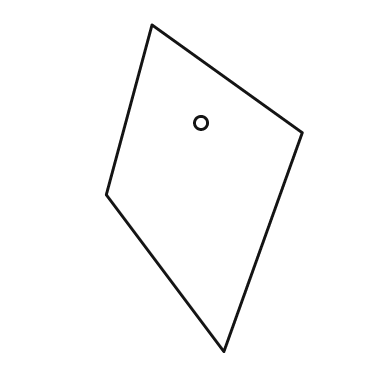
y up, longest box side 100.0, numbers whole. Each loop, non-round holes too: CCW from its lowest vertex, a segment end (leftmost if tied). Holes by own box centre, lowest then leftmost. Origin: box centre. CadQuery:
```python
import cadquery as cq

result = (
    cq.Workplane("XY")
    .moveTo(6.0, -50.0)
    .lineTo(30.0, 17.0)
    .lineTo(-16.0, 50.0)
    .lineTo(-30.0, -2.0)
    .close()
    .moveTo(-1.0, 20.0)
    .circle(2.0)
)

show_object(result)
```